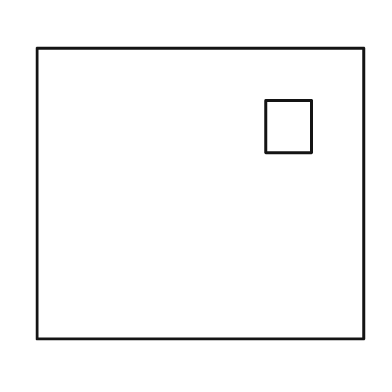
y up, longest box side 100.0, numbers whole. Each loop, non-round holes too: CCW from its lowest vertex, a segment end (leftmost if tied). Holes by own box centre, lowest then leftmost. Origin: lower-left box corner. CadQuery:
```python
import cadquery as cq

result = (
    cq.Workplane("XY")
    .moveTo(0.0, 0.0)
    .lineTo(100.0, 0.0)
    .lineTo(100.0, 89.0)
    .lineTo(0.0, 89.0)
    .close()
    .moveTo(70.0, 57.0)
    .lineTo(84.0, 57.0)
    .lineTo(84.0, 73.0)
    .lineTo(70.0, 73.0)
    .close()
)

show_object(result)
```